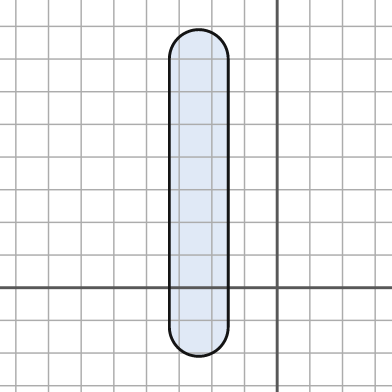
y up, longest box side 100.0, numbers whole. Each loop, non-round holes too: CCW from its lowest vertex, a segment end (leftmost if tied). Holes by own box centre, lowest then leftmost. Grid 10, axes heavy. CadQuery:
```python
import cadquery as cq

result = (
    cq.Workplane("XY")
    .moveTo(-33.0, -12.0)
    .threePointArc((-24.0, -21.0), (-15.0, -12.0))
    .lineTo(-15.0, 70.0)
    .threePointArc((-24.0, 79.0), (-33.0, 70.0))
    .close()
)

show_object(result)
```